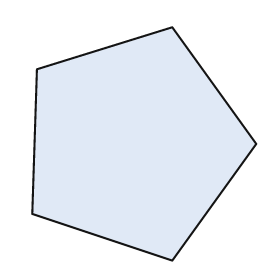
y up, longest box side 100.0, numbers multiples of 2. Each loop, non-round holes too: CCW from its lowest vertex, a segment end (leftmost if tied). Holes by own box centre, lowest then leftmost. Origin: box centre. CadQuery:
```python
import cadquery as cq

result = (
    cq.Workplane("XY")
    .moveTo(12.0, -50.0)
    .lineTo(48.0, 0.0)
    .lineTo(12.0, 50.0)
    .lineTo(-46.0, 32.0)
    .lineTo(-48.0, -30.0)
    .close()
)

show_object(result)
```